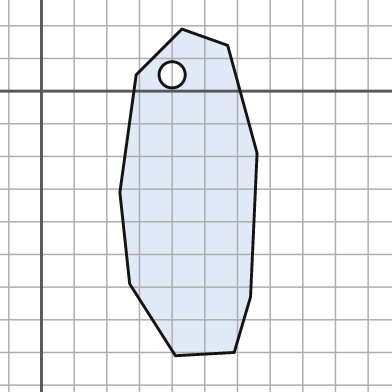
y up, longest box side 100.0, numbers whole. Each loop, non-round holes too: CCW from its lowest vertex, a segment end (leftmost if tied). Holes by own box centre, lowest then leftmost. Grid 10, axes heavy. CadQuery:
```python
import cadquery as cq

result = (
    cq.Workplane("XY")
    .moveTo(41.0, -81.0)
    .lineTo(59.0, -80.0)
    .lineTo(64.0, -63.0)
    .lineTo(66.0, -19.0)
    .lineTo(57.0, 14.0)
    .lineTo(43.0, 19.0)
    .lineTo(29.0, 5.0)
    .lineTo(24.0, -31.0)
    .lineTo(27.0, -59.0)
    .close()
    .moveTo(40.0, 5.0)
    .circle(4.0)
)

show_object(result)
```